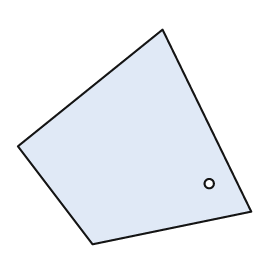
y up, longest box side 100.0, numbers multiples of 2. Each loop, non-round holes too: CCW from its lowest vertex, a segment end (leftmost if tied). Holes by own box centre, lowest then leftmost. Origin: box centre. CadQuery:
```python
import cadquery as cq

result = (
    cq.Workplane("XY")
    .moveTo(-18.0, -46.0)
    .lineTo(50.0, -32.0)
    .lineTo(12.0, 46.0)
    .lineTo(-50.0, -4.0)
    .close()
    .moveTo(32.0, -20.0)
    .circle(2.0)
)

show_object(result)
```